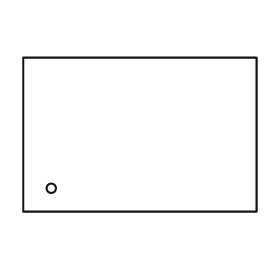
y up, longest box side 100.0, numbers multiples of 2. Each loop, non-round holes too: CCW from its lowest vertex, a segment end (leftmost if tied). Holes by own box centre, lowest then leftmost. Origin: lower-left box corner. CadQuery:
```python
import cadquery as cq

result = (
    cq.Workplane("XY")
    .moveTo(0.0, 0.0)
    .lineTo(100.0, 0.0)
    .lineTo(100.0, 66.0)
    .lineTo(0.0, 66.0)
    .close()
    .moveTo(12.0, 10.0)
    .circle(2.0)
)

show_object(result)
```